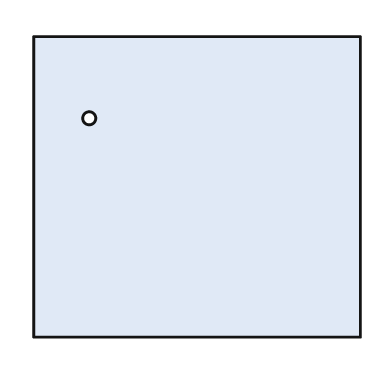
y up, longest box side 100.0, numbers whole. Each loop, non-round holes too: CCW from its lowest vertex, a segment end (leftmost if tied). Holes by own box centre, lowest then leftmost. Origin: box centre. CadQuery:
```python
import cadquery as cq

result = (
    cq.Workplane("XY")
    .moveTo(-50.0, -46.0)
    .lineTo(50.0, -46.0)
    .lineTo(50.0, 46.0)
    .lineTo(-50.0, 46.0)
    .close()
    .moveTo(-33.0, 21.0)
    .circle(2.0)
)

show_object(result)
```